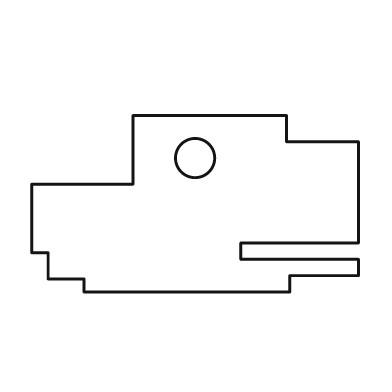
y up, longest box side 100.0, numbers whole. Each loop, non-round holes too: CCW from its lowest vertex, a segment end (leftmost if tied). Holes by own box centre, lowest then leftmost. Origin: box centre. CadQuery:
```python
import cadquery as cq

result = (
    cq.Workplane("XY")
    .moveTo(-34.0, -27.0)
    .lineTo(29.0, -27.0)
    .lineTo(29.0, -22.0)
    .lineTo(50.0, -22.0)
    .lineTo(50.0, -17.0)
    .lineTo(14.0, -17.0)
    .lineTo(14.0, -12.0)
    .lineTo(50.0, -12.0)
    .lineTo(50.0, 19.0)
    .lineTo(28.0, 19.0)
    .lineTo(28.0, 27.0)
    .lineTo(-19.0, 27.0)
    .lineTo(-19.0, 6.0)
    .lineTo(-50.0, 6.0)
    .lineTo(-50.0, -15.0)
    .lineTo(-45.0, -15.0)
    .lineTo(-45.0, -23.0)
    .lineTo(-34.0, -23.0)
    .close()
    .moveTo(0.0, 14.0)
    .circle(6.0)
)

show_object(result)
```